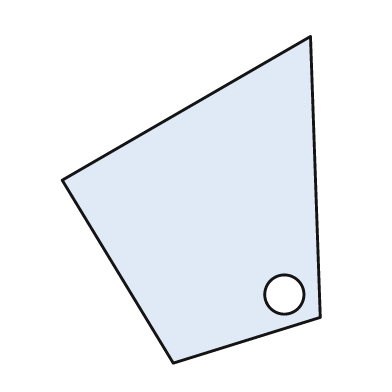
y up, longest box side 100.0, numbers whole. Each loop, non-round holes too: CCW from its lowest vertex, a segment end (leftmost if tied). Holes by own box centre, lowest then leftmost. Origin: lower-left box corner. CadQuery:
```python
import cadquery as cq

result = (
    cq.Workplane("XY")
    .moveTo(34.0, 0.0)
    .lineTo(79.0, 14.0)
    .lineTo(76.0, 100.0)
    .lineTo(0.0, 56.0)
    .close()
    .moveTo(68.0, 21.0)
    .circle(6.0)
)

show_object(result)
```